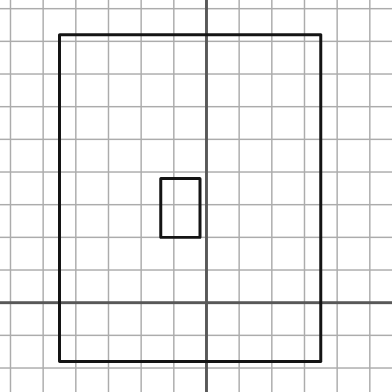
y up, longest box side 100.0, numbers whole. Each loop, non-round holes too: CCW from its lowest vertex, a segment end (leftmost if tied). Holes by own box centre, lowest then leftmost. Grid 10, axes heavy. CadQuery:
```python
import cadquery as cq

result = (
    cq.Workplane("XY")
    .moveTo(-45.0, -18.0)
    .lineTo(35.0, -18.0)
    .lineTo(35.0, 82.0)
    .lineTo(-45.0, 82.0)
    .close()
    .moveTo(-14.0, 20.0)
    .lineTo(-2.0, 20.0)
    .lineTo(-2.0, 38.0)
    .lineTo(-14.0, 38.0)
    .close()
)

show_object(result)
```